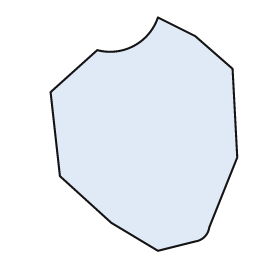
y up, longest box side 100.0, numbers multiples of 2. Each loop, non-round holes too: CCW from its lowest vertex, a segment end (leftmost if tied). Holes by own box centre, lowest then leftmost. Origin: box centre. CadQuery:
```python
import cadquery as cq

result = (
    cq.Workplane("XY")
    .moveTo(6.0, -50.0)
    .lineTo(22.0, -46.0)
    .threePointArc((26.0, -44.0), (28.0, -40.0))
    .lineTo(40.0, -10.0)
    .lineTo(38.0, 28.0)
    .lineTo(22.0, 42.0)
    .lineTo(6.0, 50.0)
    .threePointArc((-4.0, 38.0), (-20.0, 36.0))
    .lineTo(-40.0, 18.0)
    .lineTo(-36.0, -18.0)
    .lineTo(-14.0, -38.0)
    .close()
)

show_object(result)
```